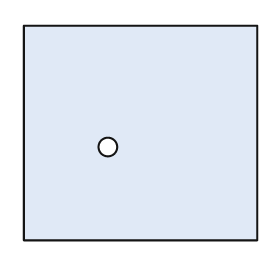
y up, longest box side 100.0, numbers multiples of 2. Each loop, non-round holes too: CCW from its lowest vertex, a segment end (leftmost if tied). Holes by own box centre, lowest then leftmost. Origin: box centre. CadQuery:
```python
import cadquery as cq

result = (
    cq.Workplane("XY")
    .moveTo(-50.0, -46.0)
    .lineTo(50.0, -46.0)
    .lineTo(50.0, 46.0)
    .lineTo(-50.0, 46.0)
    .close()
    .moveTo(-14.0, -6.0)
    .circle(4.0)
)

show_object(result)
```